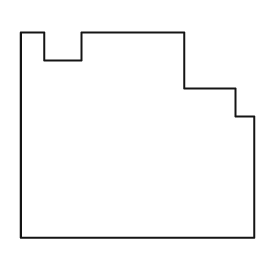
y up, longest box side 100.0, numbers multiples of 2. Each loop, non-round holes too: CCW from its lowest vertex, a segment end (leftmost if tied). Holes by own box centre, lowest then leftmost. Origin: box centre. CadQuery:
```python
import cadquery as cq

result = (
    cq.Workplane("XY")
    .moveTo(-50.0, -44.0)
    .lineTo(50.0, -44.0)
    .lineTo(50.0, 8.0)
    .lineTo(42.0, 8.0)
    .lineTo(42.0, 20.0)
    .lineTo(20.0, 20.0)
    .lineTo(20.0, 44.0)
    .lineTo(-24.0, 44.0)
    .lineTo(-24.0, 32.0)
    .lineTo(-40.0, 32.0)
    .lineTo(-40.0, 44.0)
    .lineTo(-50.0, 44.0)
    .close()
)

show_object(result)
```